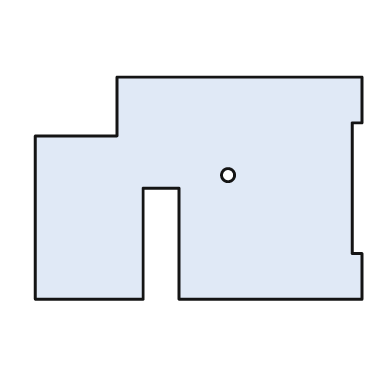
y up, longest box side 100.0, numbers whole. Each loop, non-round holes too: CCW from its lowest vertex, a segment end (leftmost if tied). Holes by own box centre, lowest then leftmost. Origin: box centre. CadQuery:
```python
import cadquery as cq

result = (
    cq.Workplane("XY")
    .moveTo(-50.0, -34.0)
    .lineTo(-17.0, -34.0)
    .lineTo(-17.0, 0.0)
    .lineTo(-6.0, 0.0)
    .lineTo(-6.0, -34.0)
    .lineTo(50.0, -34.0)
    .lineTo(50.0, -20.0)
    .lineTo(47.0, -20.0)
    .lineTo(47.0, 20.0)
    .lineTo(50.0, 20.0)
    .lineTo(50.0, 34.0)
    .lineTo(-25.0, 34.0)
    .lineTo(-25.0, 16.0)
    .lineTo(-50.0, 16.0)
    .close()
    .moveTo(9.0, 4.0)
    .circle(2.0)
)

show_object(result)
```